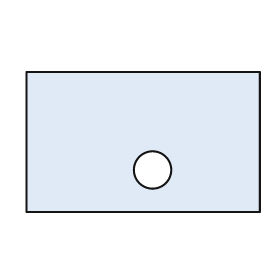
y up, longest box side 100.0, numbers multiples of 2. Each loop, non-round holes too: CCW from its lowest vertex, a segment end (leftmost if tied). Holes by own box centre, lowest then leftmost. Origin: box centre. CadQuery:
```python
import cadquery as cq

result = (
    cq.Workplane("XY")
    .moveTo(-50.0, -30.0)
    .lineTo(50.0, -30.0)
    .lineTo(50.0, 30.0)
    .lineTo(-50.0, 30.0)
    .close()
    .moveTo(4.0, -12.0)
    .circle(8.0)
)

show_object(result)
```